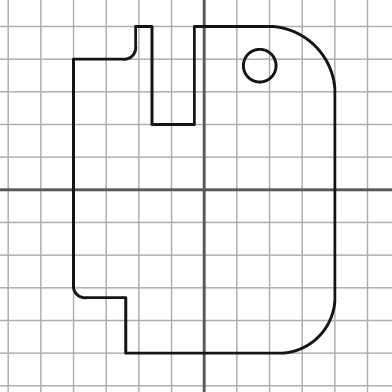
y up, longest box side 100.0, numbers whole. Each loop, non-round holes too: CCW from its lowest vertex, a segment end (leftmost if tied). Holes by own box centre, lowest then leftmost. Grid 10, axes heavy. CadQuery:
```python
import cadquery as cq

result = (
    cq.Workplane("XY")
    .moveTo(-24.0, -50.0)
    .lineTo(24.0, -50.0)
    .threePointArc((35.0, -45.0), (40.0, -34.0))
    .lineTo(40.0, 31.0)
    .threePointArc((34.0, 44.0), (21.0, 50.0))
    .lineTo(-3.0, 50.0)
    .lineTo(-3.0, 20.0)
    .lineTo(-16.0, 20.0)
    .lineTo(-16.0, 50.0)
    .lineTo(-21.0, 50.0)
    .lineTo(-21.0, 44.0)
    .threePointArc((-22.0, 41.0), (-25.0, 40.0))
    .lineTo(-40.0, 40.0)
    .lineTo(-40.0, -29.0)
    .threePointArc((-39.0, -32.0), (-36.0, -33.0))
    .lineTo(-24.0, -33.0)
    .close()
    .moveTo(17.0, 38.0)
    .circle(5.0)
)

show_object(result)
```